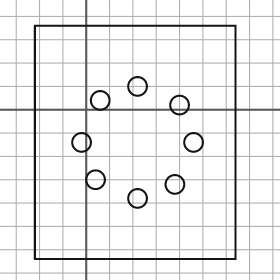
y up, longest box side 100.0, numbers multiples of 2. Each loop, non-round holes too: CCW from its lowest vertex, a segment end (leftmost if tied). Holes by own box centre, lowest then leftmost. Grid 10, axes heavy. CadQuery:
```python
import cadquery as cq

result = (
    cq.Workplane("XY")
    .moveTo(-22.0, -64.0)
    .lineTo(64.0, -64.0)
    .lineTo(64.0, 36.0)
    .lineTo(-22.0, 36.0)
    .close()
    .moveTo(22.0, -38.0)
    .circle(4.0)
    .moveTo(38.0, -32.0)
    .circle(4.0)
    .moveTo(4.0, -30.0)
    .circle(4.0)
    .moveTo(-2.0, -14.0)
    .circle(4.0)
    .moveTo(46.0, -14.0)
    .circle(4.0)
    .moveTo(40.0, 2.0)
    .circle(4.0)
    .moveTo(6.0, 4.0)
    .circle(4.0)
    .moveTo(22.0, 10.0)
    .circle(4.0)
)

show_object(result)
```